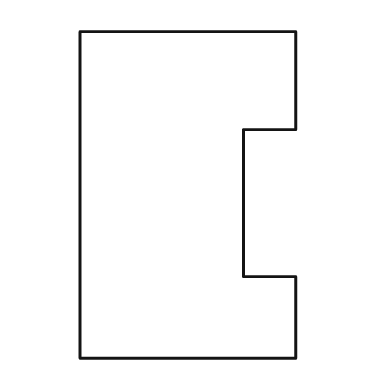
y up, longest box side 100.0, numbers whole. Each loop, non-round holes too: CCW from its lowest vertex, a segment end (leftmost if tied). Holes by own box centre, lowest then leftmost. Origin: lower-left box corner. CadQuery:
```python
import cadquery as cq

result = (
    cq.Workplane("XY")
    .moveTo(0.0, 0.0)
    .lineTo(66.0, 0.0)
    .lineTo(66.0, 25.0)
    .lineTo(50.0, 25.0)
    .lineTo(50.0, 70.0)
    .lineTo(66.0, 70.0)
    .lineTo(66.0, 100.0)
    .lineTo(0.0, 100.0)
    .close()
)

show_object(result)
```